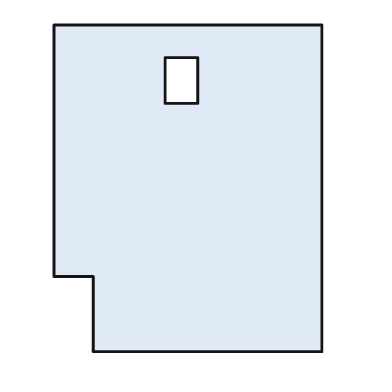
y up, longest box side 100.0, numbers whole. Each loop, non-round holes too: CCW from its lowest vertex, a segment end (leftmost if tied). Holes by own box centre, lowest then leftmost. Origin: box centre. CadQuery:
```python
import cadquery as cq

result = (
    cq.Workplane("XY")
    .moveTo(-29.0, -50.0)
    .lineTo(41.0, -50.0)
    .lineTo(41.0, 50.0)
    .lineTo(-41.0, 50.0)
    .lineTo(-41.0, -27.0)
    .lineTo(-29.0, -27.0)
    .close()
    .moveTo(-7.0, 26.0)
    .lineTo(3.0, 26.0)
    .lineTo(3.0, 40.0)
    .lineTo(-7.0, 40.0)
    .close()
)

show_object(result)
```